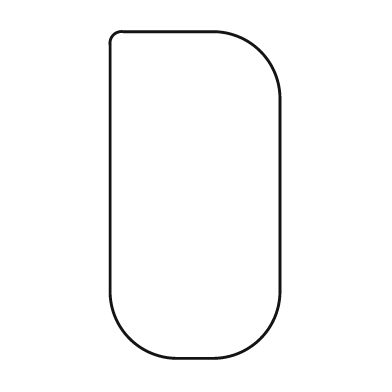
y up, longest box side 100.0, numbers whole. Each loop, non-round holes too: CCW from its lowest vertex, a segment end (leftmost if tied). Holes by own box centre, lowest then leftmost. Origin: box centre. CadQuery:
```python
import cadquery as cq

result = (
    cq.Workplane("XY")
    .moveTo(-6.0, -50.0)
    .lineTo(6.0, -50.0)
    .threePointArc((20.0, -44.0), (26.0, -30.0))
    .lineTo(26.0, 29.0)
    .threePointArc((20.0, 44.0), (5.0, 50.0))
    .lineTo(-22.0, 50.0)
    .threePointArc((-25.0, 49.0), (-26.0, 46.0))
    .lineTo(-26.0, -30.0)
    .threePointArc((-20.0, -44.0), (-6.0, -50.0))
    .close()
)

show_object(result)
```